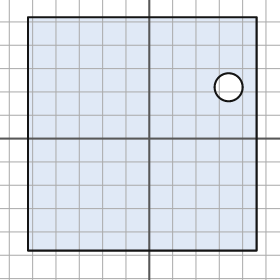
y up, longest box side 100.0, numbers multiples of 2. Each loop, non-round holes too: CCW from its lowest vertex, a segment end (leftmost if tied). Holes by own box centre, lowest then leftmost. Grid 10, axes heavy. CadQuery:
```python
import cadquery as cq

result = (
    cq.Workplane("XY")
    .moveTo(-52.0, -48.0)
    .lineTo(46.0, -48.0)
    .lineTo(46.0, 52.0)
    .lineTo(-52.0, 52.0)
    .close()
    .moveTo(34.0, 22.0)
    .circle(6.0)
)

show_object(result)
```